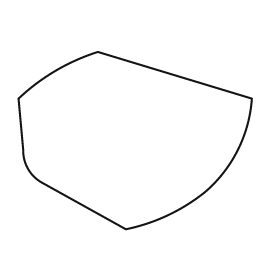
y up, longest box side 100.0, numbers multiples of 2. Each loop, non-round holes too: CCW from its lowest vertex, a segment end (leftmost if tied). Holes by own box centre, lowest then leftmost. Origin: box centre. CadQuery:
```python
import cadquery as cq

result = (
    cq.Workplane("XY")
    .moveTo(-4.0, -38.0)
    .threePointArc((14.0, -32.0), (30.0, -22.0))
    .threePointArc((44.0, -4.0), (50.0, 18.0))
    .lineTo(-16.0, 38.0)
    .threePointArc((-34.0, 30.0), (-50.0, 18.0))
    .lineTo(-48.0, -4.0)
    .threePointArc((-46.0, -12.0), (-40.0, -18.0))
    .close()
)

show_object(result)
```